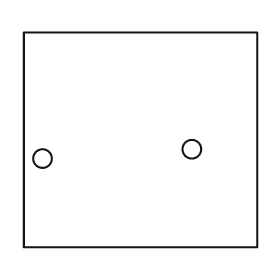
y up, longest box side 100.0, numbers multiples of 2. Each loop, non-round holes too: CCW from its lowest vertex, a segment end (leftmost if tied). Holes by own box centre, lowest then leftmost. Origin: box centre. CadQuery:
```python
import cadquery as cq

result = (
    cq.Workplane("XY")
    .moveTo(-50.0, -46.0)
    .lineTo(50.0, -46.0)
    .lineTo(50.0, 46.0)
    .lineTo(-50.0, 46.0)
    .close()
    .moveTo(-42.0, -8.0)
    .circle(4.0)
    .moveTo(22.0, -4.0)
    .circle(4.0)
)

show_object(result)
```